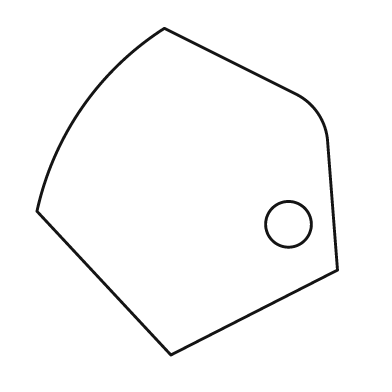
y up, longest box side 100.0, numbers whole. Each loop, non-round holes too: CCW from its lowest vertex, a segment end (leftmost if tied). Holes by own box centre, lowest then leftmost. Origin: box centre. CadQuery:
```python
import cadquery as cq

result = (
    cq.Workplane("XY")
    .moveTo(-5.0, -50.0)
    .lineTo(46.0, -24.0)
    .lineTo(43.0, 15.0)
    .threePointArc((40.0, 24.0), (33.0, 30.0))
    .lineTo(-7.0, 50.0)
    .threePointArc((-32.0, 26.0), (-46.0, -6.0))
    .close()
    .moveTo(31.0, -10.0)
    .circle(7.0)
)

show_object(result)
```